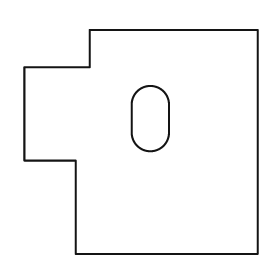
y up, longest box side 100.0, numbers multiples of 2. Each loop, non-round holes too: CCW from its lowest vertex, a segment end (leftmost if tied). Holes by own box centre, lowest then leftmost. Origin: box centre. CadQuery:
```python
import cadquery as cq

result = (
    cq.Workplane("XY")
    .moveTo(-28.0, -48.0)
    .lineTo(50.0, -48.0)
    .lineTo(50.0, 48.0)
    .lineTo(-22.0, 48.0)
    .lineTo(-22.0, 32.0)
    .lineTo(-50.0, 32.0)
    .lineTo(-50.0, -8.0)
    .lineTo(-28.0, -8.0)
    .close()
    .moveTo(-4.0, 4.0)
    .threePointArc((4.0, -4.0), (12.0, 4.0))
    .lineTo(12.0, 16.0)
    .threePointArc((4.0, 24.0), (-4.0, 16.0))
    .close()
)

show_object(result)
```